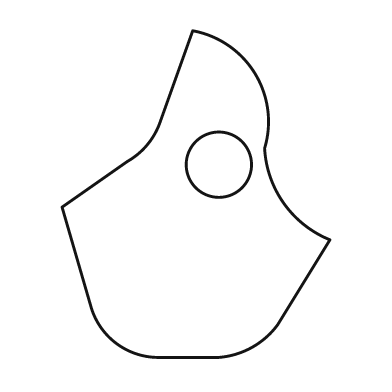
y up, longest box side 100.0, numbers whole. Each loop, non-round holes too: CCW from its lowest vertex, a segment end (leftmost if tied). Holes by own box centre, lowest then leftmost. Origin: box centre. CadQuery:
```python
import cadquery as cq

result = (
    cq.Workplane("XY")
    .moveTo(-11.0, -50.0)
    .lineTo(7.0, -50.0)
    .threePointArc((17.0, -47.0), (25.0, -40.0))
    .lineTo(41.0, -14.0)
    .threePointArc((27.0, -3.0), (21.0, 14.0))
    .threePointArc((18.0, 37.0), (-1.0, 50.0))
    .lineTo(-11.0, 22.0)
    .threePointArc((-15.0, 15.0), (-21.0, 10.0))
    .lineTo(-41.0, -4.0)
    .lineTo(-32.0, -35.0)
    .threePointArc((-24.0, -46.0), (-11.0, -50.0))
    .close()
    .moveTo(7.0, 9.0)
    .circle(10.0)
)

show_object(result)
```